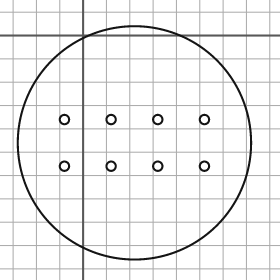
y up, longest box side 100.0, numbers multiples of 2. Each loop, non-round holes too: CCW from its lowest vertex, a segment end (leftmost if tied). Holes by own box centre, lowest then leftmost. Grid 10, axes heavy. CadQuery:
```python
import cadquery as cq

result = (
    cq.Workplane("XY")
    .moveTo(22.0, -46.0)
    .circle(50.0)
    .moveTo(-8.0, -56.0)
    .circle(2.0)
    .moveTo(12.0, -56.0)
    .circle(2.0)
    .moveTo(32.0, -56.0)
    .circle(2.0)
    .moveTo(52.0, -56.0)
    .circle(2.0)
    .moveTo(-8.0, -36.0)
    .circle(2.0)
    .moveTo(12.0, -36.0)
    .circle(2.0)
    .moveTo(32.0, -36.0)
    .circle(2.0)
    .moveTo(52.0, -36.0)
    .circle(2.0)
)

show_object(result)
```